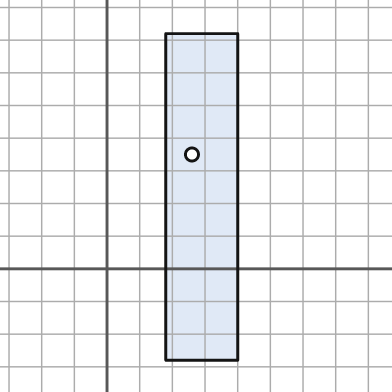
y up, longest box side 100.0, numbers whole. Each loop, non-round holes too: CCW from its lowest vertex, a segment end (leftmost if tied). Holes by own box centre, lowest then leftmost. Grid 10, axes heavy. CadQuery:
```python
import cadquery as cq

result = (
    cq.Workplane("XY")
    .moveTo(18.0, -28.0)
    .lineTo(40.0, -28.0)
    .lineTo(40.0, 72.0)
    .lineTo(18.0, 72.0)
    .close()
    .moveTo(26.0, 35.0)
    .circle(2.0)
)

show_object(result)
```